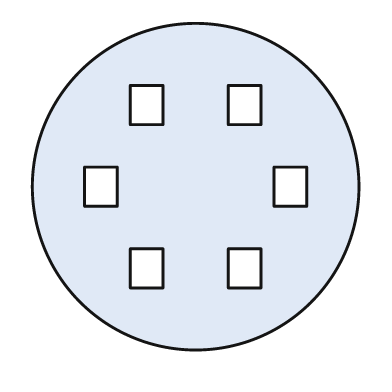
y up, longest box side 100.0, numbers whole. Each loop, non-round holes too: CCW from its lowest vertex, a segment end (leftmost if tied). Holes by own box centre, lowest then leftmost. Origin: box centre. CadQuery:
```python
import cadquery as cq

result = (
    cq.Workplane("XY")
    .moveTo(0.0, 0.0)
    .circle(50.0)
    .moveTo(-20.0, -31.0)
    .lineTo(-10.0, -31.0)
    .lineTo(-10.0, -19.0)
    .lineTo(-20.0, -19.0)
    .close()
    .moveTo(10.0, -31.0)
    .lineTo(20.0, -31.0)
    .lineTo(20.0, -19.0)
    .lineTo(10.0, -19.0)
    .close()
    .moveTo(-34.0, -6.0)
    .lineTo(-24.0, -6.0)
    .lineTo(-24.0, 6.0)
    .lineTo(-34.0, 6.0)
    .close()
    .moveTo(24.0, -6.0)
    .lineTo(34.0, -6.0)
    .lineTo(34.0, 6.0)
    .lineTo(24.0, 6.0)
    .close()
    .moveTo(-20.0, 19.0)
    .lineTo(-10.0, 19.0)
    .lineTo(-10.0, 31.0)
    .lineTo(-20.0, 31.0)
    .close()
    .moveTo(10.0, 19.0)
    .lineTo(20.0, 19.0)
    .lineTo(20.0, 31.0)
    .lineTo(10.0, 31.0)
    .close()
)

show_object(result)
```